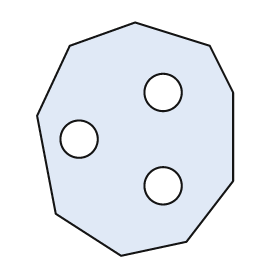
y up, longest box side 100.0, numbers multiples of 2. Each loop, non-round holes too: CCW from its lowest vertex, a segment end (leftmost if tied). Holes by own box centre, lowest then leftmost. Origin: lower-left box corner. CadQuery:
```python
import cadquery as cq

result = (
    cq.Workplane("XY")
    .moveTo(36.0, 0.0)
    .lineTo(64.0, 6.0)
    .lineTo(84.0, 32.0)
    .lineTo(84.0, 70.0)
    .lineTo(74.0, 90.0)
    .lineTo(42.0, 100.0)
    .lineTo(14.0, 90.0)
    .lineTo(0.0, 60.0)
    .lineTo(8.0, 18.0)
    .close()
    .moveTo(54.0, 30.0)
    .circle(8.0)
    .moveTo(18.0, 50.0)
    .circle(8.0)
    .moveTo(54.0, 70.0)
    .circle(8.0)
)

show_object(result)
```